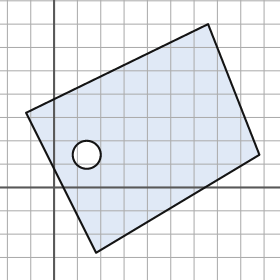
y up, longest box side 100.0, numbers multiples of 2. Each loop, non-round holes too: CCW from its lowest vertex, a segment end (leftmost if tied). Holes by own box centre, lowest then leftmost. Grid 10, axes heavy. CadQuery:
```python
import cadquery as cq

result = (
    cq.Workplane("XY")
    .moveTo(18.0, -28.0)
    .lineTo(88.0, 14.0)
    .lineTo(66.0, 70.0)
    .lineTo(-12.0, 32.0)
    .close()
    .moveTo(14.0, 14.0)
    .circle(6.0)
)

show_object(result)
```